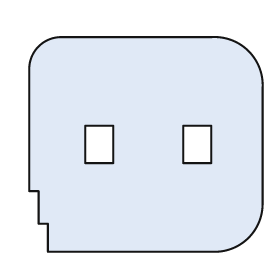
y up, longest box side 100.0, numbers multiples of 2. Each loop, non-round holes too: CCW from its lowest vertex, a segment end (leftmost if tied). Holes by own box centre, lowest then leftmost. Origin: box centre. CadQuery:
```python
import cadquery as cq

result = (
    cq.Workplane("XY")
    .moveTo(-42.0, -46.0)
    .lineTo(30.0, -46.0)
    .threePointArc((44.0, -40.0), (50.0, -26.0))
    .lineTo(50.0, 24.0)
    .threePointArc((44.0, 40.0), (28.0, 46.0))
    .lineTo(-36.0, 46.0)
    .threePointArc((-46.0, 42.0), (-50.0, 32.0))
    .lineTo(-50.0, -20.0)
    .lineTo(-46.0, -20.0)
    .lineTo(-46.0, -34.0)
    .lineTo(-42.0, -34.0)
    .close()
    .moveTo(-26.0, -8.0)
    .lineTo(-14.0, -8.0)
    .lineTo(-14.0, 8.0)
    .lineTo(-26.0, 8.0)
    .close()
    .moveTo(16.0, -8.0)
    .lineTo(28.0, -8.0)
    .lineTo(28.0, 8.0)
    .lineTo(16.0, 8.0)
    .close()
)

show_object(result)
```